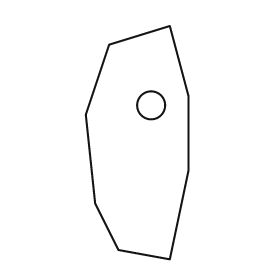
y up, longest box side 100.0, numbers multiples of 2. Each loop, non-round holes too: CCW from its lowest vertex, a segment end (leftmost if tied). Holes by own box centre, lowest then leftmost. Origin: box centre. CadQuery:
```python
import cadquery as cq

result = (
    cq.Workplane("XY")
    .moveTo(14.0, -50.0)
    .lineTo(22.0, -12.0)
    .lineTo(22.0, 20.0)
    .lineTo(14.0, 50.0)
    .lineTo(-12.0, 42.0)
    .lineTo(-22.0, 12.0)
    .lineTo(-18.0, -26.0)
    .lineTo(-8.0, -46.0)
    .close()
    .moveTo(6.0, 16.0)
    .circle(6.0)
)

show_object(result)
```